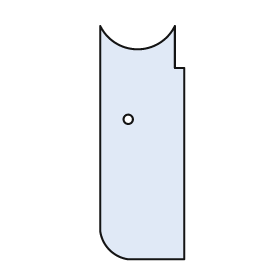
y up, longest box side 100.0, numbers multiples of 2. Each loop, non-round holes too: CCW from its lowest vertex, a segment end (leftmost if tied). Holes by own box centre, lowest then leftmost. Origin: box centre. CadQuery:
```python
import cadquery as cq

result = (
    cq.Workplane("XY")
    .moveTo(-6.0, -50.0)
    .lineTo(18.0, -50.0)
    .lineTo(18.0, 32.0)
    .lineTo(14.0, 32.0)
    .lineTo(14.0, 50.0)
    .threePointArc((-2.0, 40.0), (-18.0, 50.0))
    .lineTo(-18.0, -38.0)
    .threePointArc((-14.0, -46.0), (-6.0, -50.0))
    .close()
    .moveTo(-6.0, 10.0)
    .circle(2.0)
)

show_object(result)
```